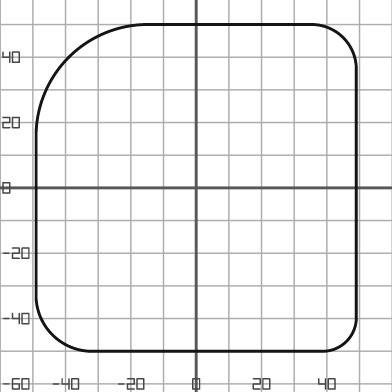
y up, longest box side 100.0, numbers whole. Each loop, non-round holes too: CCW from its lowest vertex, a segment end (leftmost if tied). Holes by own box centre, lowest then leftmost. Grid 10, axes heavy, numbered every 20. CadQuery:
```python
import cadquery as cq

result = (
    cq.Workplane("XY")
    .moveTo(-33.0, -50.0)
    .lineTo(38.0, -50.0)
    .threePointArc((46.0, -47.0), (49.0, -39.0))
    .lineTo(49.0, 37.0)
    .threePointArc((45.0, 46.0), (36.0, 50.0))
    .lineTo(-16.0, 50.0)
    .threePointArc((-39.0, 40.0), (-49.0, 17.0))
    .lineTo(-49.0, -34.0)
    .threePointArc((-44.0, -45.0), (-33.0, -50.0))
    .close()
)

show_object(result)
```